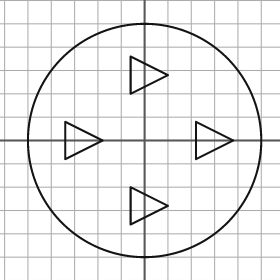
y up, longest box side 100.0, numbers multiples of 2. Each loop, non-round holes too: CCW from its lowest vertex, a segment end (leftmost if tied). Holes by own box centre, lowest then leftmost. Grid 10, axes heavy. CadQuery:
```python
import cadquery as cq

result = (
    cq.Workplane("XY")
    .moveTo(0.0, 0.0)
    .circle(50.0)
    .moveTo(-6.0, -36.0)
    .lineTo(10.0, -28.0)
    .lineTo(-6.0, -20.0)
    .close()
    .moveTo(-34.0, -8.0)
    .lineTo(-18.0, 0.0)
    .lineTo(-34.0, 8.0)
    .close()
    .moveTo(22.0, -8.0)
    .lineTo(38.0, 0.0)
    .lineTo(22.0, 8.0)
    .close()
    .moveTo(-6.0, 20.0)
    .lineTo(10.0, 28.0)
    .lineTo(-6.0, 36.0)
    .close()
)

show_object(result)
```